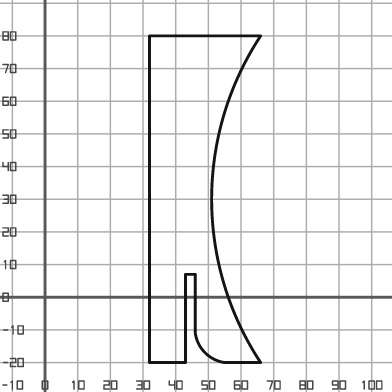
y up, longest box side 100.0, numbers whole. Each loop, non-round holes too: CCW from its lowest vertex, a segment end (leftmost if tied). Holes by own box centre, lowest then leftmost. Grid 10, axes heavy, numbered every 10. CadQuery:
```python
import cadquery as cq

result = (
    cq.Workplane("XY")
    .moveTo(32.0, -20.0)
    .lineTo(43.0, -20.0)
    .lineTo(43.0, 7.0)
    .lineTo(46.0, 7.0)
    .lineTo(46.0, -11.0)
    .threePointArc((49.0, -17.0), (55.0, -20.0))
    .lineTo(66.0, -20.0)
    .threePointArc((51.0, 30.0), (66.0, 80.0))
    .lineTo(32.0, 80.0)
    .close()
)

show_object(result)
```